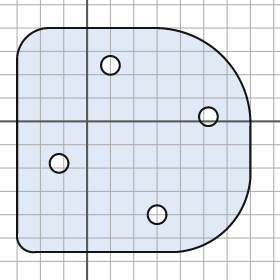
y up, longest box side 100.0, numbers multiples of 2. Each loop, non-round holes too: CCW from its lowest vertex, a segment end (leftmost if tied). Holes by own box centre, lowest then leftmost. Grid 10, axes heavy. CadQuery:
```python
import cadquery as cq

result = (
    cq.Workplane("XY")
    .moveTo(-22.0, -56.0)
    .lineTo(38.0, -56.0)
    .threePointArc((60.0, -46.0), (70.0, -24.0))
    .lineTo(70.0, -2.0)
    .threePointArc((58.0, 28.0), (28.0, 40.0))
    .lineTo(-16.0, 40.0)
    .threePointArc((-26.0, 36.0), (-30.0, 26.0))
    .lineTo(-30.0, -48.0)
    .threePointArc((-28.0, -54.0), (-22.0, -56.0))
    .close()
    .moveTo(30.0, -40.0)
    .circle(4.0)
    .moveTo(-12.0, -18.0)
    .circle(4.0)
    .moveTo(52.0, 2.0)
    .circle(4.0)
    .moveTo(10.0, 24.0)
    .circle(4.0)
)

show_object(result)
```